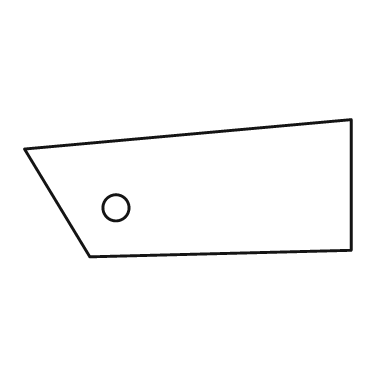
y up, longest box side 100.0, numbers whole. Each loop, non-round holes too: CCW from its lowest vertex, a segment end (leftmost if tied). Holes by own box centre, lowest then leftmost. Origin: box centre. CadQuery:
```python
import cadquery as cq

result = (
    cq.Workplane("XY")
    .moveTo(-30.0, -21.0)
    .lineTo(50.0, -19.0)
    .lineTo(50.0, 21.0)
    .lineTo(-50.0, 12.0)
    .close()
    .moveTo(-22.0, -6.0)
    .circle(4.0)
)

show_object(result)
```